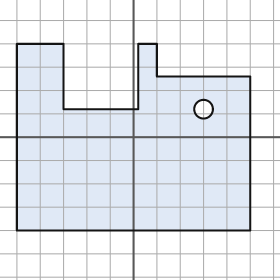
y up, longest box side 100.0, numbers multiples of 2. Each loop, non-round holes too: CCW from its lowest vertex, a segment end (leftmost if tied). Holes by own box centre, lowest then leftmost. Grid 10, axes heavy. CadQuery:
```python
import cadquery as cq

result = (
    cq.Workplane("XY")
    .moveTo(-50.0, -40.0)
    .lineTo(50.0, -40.0)
    .lineTo(50.0, 26.0)
    .lineTo(10.0, 26.0)
    .lineTo(10.0, 40.0)
    .lineTo(2.0, 40.0)
    .lineTo(2.0, 12.0)
    .lineTo(-30.0, 12.0)
    .lineTo(-30.0, 40.0)
    .lineTo(-50.0, 40.0)
    .close()
    .moveTo(30.0, 12.0)
    .circle(4.0)
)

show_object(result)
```